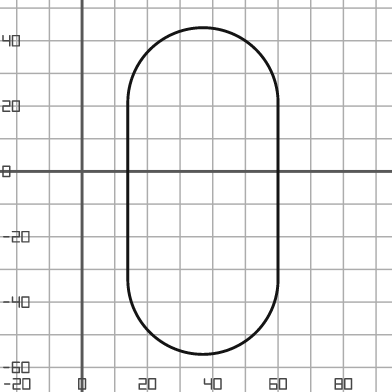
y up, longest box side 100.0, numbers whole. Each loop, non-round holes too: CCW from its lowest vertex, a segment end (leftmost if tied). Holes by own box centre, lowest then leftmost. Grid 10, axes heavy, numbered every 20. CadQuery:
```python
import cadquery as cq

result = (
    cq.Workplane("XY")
    .moveTo(14.0, -33.0)
    .threePointArc((37.0, -56.0), (60.0, -33.0))
    .lineTo(60.0, 21.0)
    .threePointArc((37.0, 44.0), (14.0, 21.0))
    .close()
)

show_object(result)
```